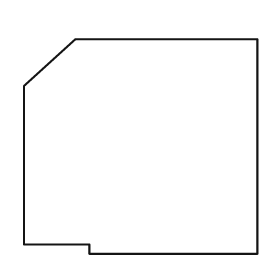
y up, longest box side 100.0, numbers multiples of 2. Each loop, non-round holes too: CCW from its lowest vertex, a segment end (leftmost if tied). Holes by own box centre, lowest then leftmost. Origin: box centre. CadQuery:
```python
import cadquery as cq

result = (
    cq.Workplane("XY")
    .moveTo(-22.0, -46.0)
    .lineTo(50.0, -46.0)
    .lineTo(50.0, 46.0)
    .lineTo(-28.0, 46.0)
    .lineTo(-50.0, 26.0)
    .lineTo(-50.0, -42.0)
    .lineTo(-22.0, -42.0)
    .close()
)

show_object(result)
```